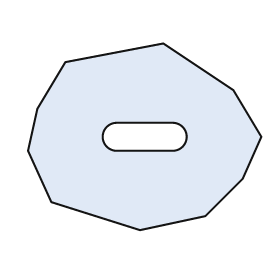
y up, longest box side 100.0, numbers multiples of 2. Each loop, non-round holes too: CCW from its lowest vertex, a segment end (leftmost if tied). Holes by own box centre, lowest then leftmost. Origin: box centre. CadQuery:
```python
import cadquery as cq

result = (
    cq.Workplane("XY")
    .moveTo(-2.0, -40.0)
    .lineTo(26.0, -34.0)
    .lineTo(42.0, -18.0)
    .lineTo(50.0, 0.0)
    .lineTo(38.0, 20.0)
    .lineTo(8.0, 40.0)
    .lineTo(-34.0, 32.0)
    .lineTo(-46.0, 12.0)
    .lineTo(-50.0, -6.0)
    .lineTo(-40.0, -28.0)
    .close()
    .moveTo(-12.0, -6.0)
    .lineTo(12.0, -6.0)
    .threePointArc((18.0, 0.0), (12.0, 6.0))
    .lineTo(-12.0, 6.0)
    .threePointArc((-18.0, 0.0), (-12.0, -6.0))
    .close()
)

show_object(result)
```